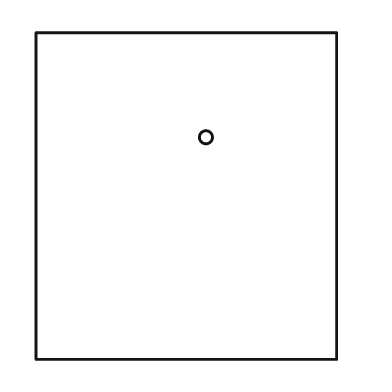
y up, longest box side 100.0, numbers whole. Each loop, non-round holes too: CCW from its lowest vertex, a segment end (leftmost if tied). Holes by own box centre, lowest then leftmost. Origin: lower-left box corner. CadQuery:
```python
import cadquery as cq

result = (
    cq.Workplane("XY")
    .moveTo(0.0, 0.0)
    .lineTo(92.0, 0.0)
    .lineTo(92.0, 100.0)
    .lineTo(0.0, 100.0)
    .close()
    .moveTo(52.0, 68.0)
    .circle(2.0)
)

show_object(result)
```